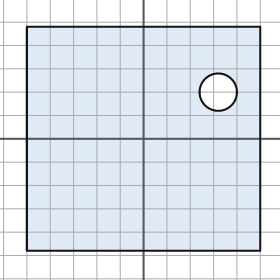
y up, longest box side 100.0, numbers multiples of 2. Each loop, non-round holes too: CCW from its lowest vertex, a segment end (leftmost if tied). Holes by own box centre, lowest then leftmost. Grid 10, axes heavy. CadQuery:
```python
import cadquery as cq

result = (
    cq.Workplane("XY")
    .moveTo(-50.0, -48.0)
    .lineTo(50.0, -48.0)
    .lineTo(50.0, 48.0)
    .lineTo(-50.0, 48.0)
    .close()
    .moveTo(32.0, 20.0)
    .circle(8.0)
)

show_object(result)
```